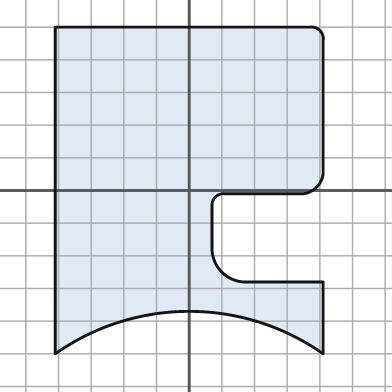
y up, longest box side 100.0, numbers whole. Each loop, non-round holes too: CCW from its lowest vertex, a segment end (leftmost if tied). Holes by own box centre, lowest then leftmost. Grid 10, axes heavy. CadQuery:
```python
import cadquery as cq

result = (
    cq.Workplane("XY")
    .moveTo(-41.0, -50.0)
    .threePointArc((0.0, -37.0), (41.0, -50.0))
    .lineTo(41.0, -28.0)
    .lineTo(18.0, -28.0)
    .threePointArc((10.0, -25.0), (7.0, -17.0))
    .lineTo(7.0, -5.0)
    .threePointArc((8.0, -2.0), (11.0, -1.0))
    .lineTo(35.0, -1.0)
    .threePointArc((39.0, 1.0), (41.0, 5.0))
    .lineTo(41.0, 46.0)
    .threePointArc((40.0, 49.0), (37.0, 50.0))
    .lineTo(-41.0, 50.0)
    .close()
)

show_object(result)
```